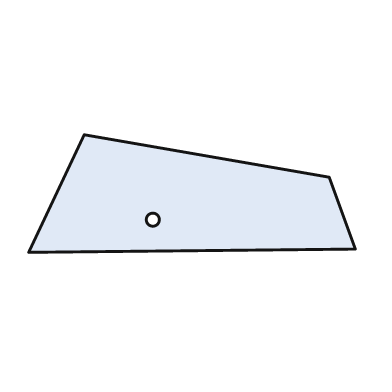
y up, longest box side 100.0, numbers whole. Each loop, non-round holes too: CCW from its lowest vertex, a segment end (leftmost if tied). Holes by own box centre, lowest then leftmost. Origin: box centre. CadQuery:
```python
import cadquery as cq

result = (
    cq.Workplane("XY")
    .moveTo(-50.0, -18.0)
    .lineTo(50.0, -17.0)
    .lineTo(42.0, 5.0)
    .lineTo(-33.0, 18.0)
    .close()
    .moveTo(-12.0, -8.0)
    .circle(2.0)
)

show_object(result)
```